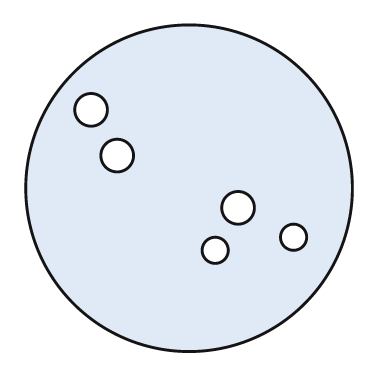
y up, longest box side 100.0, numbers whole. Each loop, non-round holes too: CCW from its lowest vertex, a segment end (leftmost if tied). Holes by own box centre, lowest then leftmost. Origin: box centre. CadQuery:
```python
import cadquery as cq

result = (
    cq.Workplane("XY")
    .moveTo(0.0, 0.0)
    .circle(50.0)
    .moveTo(8.0, -19.0)
    .circle(4.0)
    .moveTo(32.0, -15.0)
    .circle(4.0)
    .moveTo(15.0, -6.0)
    .circle(5.0)
    .moveTo(-22.0, 10.0)
    .circle(5.0)
    .moveTo(-30.0, 24.0)
    .circle(5.0)
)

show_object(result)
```